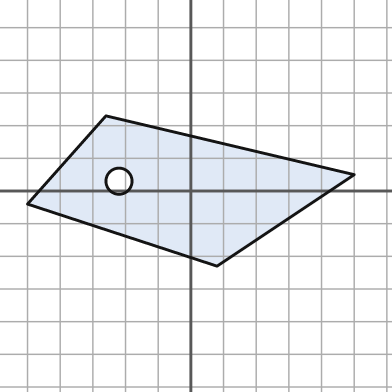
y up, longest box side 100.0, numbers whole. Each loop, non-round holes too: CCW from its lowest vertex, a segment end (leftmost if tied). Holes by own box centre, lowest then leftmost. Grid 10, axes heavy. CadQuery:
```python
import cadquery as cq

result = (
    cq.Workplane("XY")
    .moveTo(8.0, -23.0)
    .lineTo(50.0, 5.0)
    .lineTo(-26.0, 23.0)
    .lineTo(-50.0, -4.0)
    .close()
    .moveTo(-22.0, 3.0)
    .circle(4.0)
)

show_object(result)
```